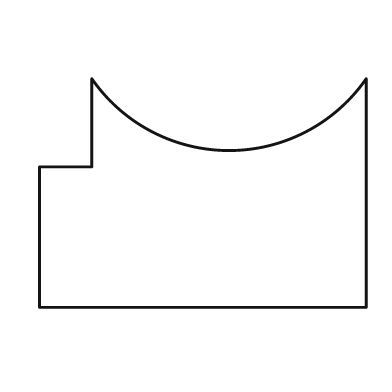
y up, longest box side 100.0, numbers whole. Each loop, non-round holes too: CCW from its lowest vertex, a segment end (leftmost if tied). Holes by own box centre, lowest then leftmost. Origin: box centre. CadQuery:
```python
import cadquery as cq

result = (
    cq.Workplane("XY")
    .moveTo(-50.0, -35.0)
    .lineTo(50.0, -35.0)
    .lineTo(50.0, 35.0)
    .threePointArc((8.0, 13.0), (-34.0, 35.0))
    .lineTo(-34.0, 8.0)
    .lineTo(-50.0, 8.0)
    .close()
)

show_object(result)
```